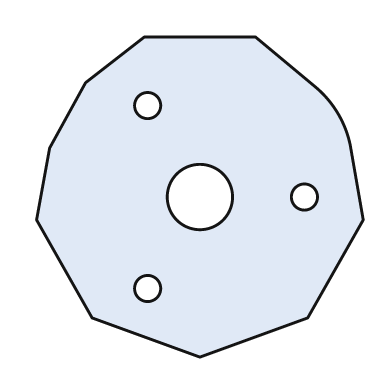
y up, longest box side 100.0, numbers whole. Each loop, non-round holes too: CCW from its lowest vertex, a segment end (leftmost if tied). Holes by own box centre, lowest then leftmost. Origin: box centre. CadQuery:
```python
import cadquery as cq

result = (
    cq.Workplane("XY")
    .moveTo(0.0, -49.0)
    .lineTo(33.0, -37.0)
    .lineTo(50.0, -7.0)
    .lineTo(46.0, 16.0)
    .threePointArc((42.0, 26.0), (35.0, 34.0))
    .lineTo(17.0, 49.0)
    .lineTo(-17.0, 49.0)
    .lineTo(-35.0, 35.0)
    .lineTo(-46.0, 15.0)
    .lineTo(-50.0, -7.0)
    .lineTo(-33.0, -37.0)
    .close()
    .moveTo(-16.0, -28.0)
    .circle(4.0)
    .moveTo(0.0, 0.0)
    .circle(10.0)
    .moveTo(32.0, 0.0)
    .circle(4.0)
    .moveTo(-16.0, 28.0)
    .circle(4.0)
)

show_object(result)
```